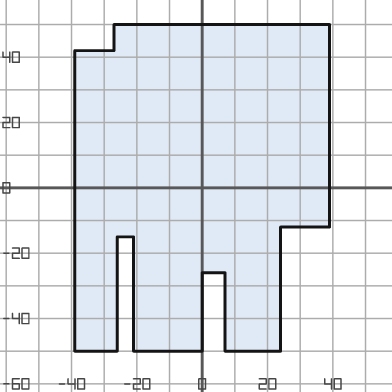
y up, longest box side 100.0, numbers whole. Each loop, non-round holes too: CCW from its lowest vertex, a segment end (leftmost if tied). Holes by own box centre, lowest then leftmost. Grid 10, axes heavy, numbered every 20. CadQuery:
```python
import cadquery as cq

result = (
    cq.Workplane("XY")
    .moveTo(-39.0, -50.0)
    .lineTo(-26.0, -50.0)
    .lineTo(-26.0, -15.0)
    .lineTo(-21.0, -15.0)
    .lineTo(-21.0, -50.0)
    .lineTo(0.0, -50.0)
    .lineTo(0.0, -26.0)
    .lineTo(7.0, -26.0)
    .lineTo(7.0, -50.0)
    .lineTo(24.0, -50.0)
    .lineTo(24.0, -12.0)
    .lineTo(39.0, -12.0)
    .lineTo(39.0, 50.0)
    .lineTo(-27.0, 50.0)
    .lineTo(-27.0, 42.0)
    .lineTo(-39.0, 42.0)
    .close()
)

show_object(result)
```